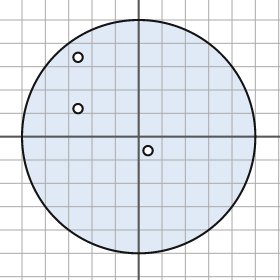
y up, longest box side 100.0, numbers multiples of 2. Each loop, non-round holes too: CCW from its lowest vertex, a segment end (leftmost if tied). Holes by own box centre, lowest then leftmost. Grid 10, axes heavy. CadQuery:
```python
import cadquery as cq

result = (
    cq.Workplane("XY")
    .moveTo(0.0, 0.0)
    .circle(50.0)
    .moveTo(4.0, -6.0)
    .circle(2.0)
    .moveTo(-26.0, 12.0)
    .circle(2.0)
    .moveTo(-26.0, 34.0)
    .circle(2.0)
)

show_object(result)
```